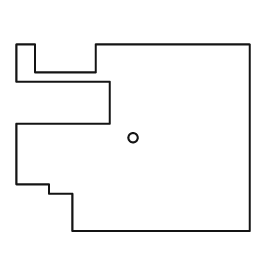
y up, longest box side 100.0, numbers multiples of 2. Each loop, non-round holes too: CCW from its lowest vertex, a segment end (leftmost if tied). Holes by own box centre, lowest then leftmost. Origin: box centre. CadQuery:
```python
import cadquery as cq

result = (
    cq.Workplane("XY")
    .moveTo(-26.0, -40.0)
    .lineTo(50.0, -40.0)
    .lineTo(50.0, 40.0)
    .lineTo(-16.0, 40.0)
    .lineTo(-16.0, 28.0)
    .lineTo(-42.0, 28.0)
    .lineTo(-42.0, 40.0)
    .lineTo(-50.0, 40.0)
    .lineTo(-50.0, 24.0)
    .lineTo(-10.0, 24.0)
    .lineTo(-10.0, 6.0)
    .lineTo(-50.0, 6.0)
    .lineTo(-50.0, -20.0)
    .lineTo(-36.0, -20.0)
    .lineTo(-36.0, -24.0)
    .lineTo(-26.0, -24.0)
    .close()
    .moveTo(0.0, 0.0)
    .circle(2.0)
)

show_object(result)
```